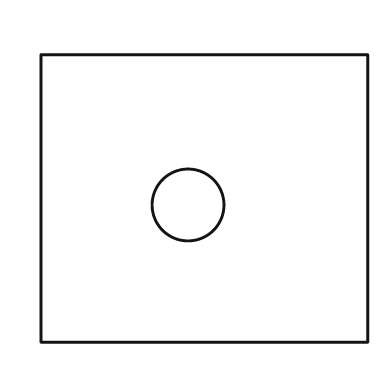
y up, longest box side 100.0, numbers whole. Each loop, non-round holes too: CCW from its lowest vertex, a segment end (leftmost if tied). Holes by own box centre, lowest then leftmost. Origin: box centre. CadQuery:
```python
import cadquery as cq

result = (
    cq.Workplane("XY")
    .moveTo(-50.0, -44.0)
    .lineTo(50.0, -44.0)
    .lineTo(50.0, 44.0)
    .lineTo(-50.0, 44.0)
    .close()
    .moveTo(-5.0, -2.0)
    .circle(11.0)
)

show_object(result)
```